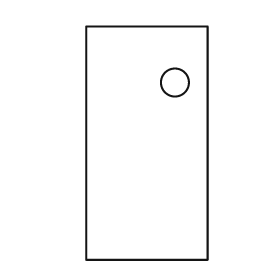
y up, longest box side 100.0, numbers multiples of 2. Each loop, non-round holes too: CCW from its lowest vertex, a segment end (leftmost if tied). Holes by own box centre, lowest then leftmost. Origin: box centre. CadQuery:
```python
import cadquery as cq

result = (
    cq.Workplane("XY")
    .moveTo(-26.0, -50.0)
    .lineTo(26.0, -50.0)
    .lineTo(26.0, 50.0)
    .lineTo(-26.0, 50.0)
    .close()
    .moveTo(12.0, 26.0)
    .circle(6.0)
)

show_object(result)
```